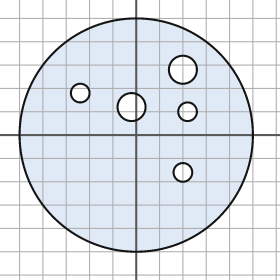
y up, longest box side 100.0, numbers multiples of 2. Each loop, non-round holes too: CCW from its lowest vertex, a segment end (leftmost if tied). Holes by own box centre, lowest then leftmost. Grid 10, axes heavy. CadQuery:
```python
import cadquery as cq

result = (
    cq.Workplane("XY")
    .moveTo(0.0, 0.0)
    .circle(50.0)
    .moveTo(20.0, -16.0)
    .circle(4.0)
    .moveTo(22.0, 10.0)
    .circle(4.0)
    .moveTo(-2.0, 12.0)
    .circle(6.0)
    .moveTo(-24.0, 18.0)
    .circle(4.0)
    .moveTo(20.0, 28.0)
    .circle(6.0)
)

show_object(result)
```